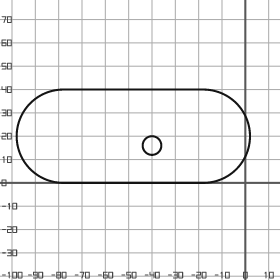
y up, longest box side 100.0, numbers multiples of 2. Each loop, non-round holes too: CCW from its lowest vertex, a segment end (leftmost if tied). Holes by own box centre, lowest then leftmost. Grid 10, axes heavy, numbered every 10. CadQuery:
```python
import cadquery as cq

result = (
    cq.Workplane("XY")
    .moveTo(-78.0, 0.0)
    .lineTo(-18.0, 0.0)
    .threePointArc((2.0, 20.0), (-18.0, 40.0))
    .lineTo(-78.0, 40.0)
    .threePointArc((-98.0, 20.0), (-78.0, 0.0))
    .close()
    .moveTo(-40.0, 16.0)
    .circle(4.0)
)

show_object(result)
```